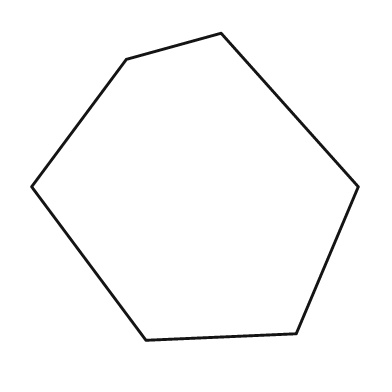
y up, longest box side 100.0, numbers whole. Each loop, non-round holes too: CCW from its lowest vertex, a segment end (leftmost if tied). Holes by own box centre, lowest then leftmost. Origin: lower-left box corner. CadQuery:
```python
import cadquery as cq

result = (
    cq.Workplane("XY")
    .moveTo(35.0, 0.0)
    .lineTo(81.0, 2.0)
    .lineTo(100.0, 47.0)
    .lineTo(58.0, 94.0)
    .lineTo(29.0, 86.0)
    .lineTo(0.0, 47.0)
    .close()
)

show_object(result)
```